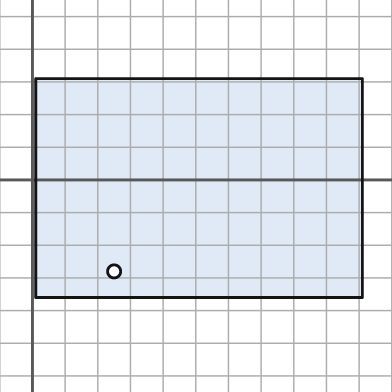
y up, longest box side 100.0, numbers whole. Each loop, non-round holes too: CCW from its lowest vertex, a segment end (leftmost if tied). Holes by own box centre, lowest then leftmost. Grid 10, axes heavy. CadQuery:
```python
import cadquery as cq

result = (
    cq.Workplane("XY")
    .moveTo(1.0, -36.0)
    .lineTo(101.0, -36.0)
    .lineTo(101.0, 31.0)
    .lineTo(1.0, 31.0)
    .close()
    .moveTo(25.0, -28.0)
    .circle(2.0)
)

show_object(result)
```